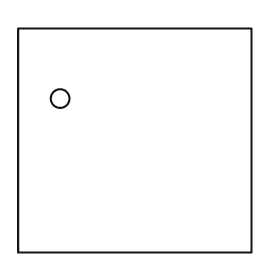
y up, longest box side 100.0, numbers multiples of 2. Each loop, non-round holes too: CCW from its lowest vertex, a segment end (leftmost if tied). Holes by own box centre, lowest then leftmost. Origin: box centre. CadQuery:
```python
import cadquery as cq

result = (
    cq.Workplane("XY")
    .moveTo(-50.0, -48.0)
    .lineTo(50.0, -48.0)
    .lineTo(50.0, 48.0)
    .lineTo(-50.0, 48.0)
    .close()
    .moveTo(-32.0, 18.0)
    .circle(4.0)
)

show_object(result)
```